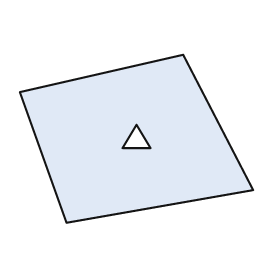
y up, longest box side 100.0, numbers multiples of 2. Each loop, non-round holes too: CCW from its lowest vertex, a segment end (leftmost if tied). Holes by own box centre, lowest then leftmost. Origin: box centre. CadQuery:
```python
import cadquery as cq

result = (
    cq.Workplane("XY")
    .moveTo(-30.0, -36.0)
    .lineTo(50.0, -22.0)
    .lineTo(20.0, 36.0)
    .lineTo(-50.0, 20.0)
    .close()
    .moveTo(-6.0, -4.0)
    .lineTo(6.0, -4.0)
    .lineTo(0.0, 6.0)
    .close()
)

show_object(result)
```